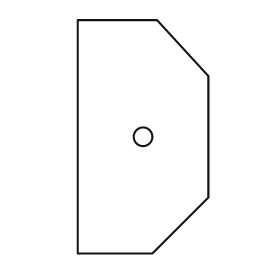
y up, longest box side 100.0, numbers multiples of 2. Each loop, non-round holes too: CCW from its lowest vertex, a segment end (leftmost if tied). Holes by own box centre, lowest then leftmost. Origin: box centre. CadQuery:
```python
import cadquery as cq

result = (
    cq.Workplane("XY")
    .moveTo(-28.0, -50.0)
    .lineTo(4.0, -50.0)
    .lineTo(28.0, -26.0)
    .lineTo(28.0, 26.0)
    .lineTo(6.0, 50.0)
    .lineTo(-28.0, 50.0)
    .close()
    .moveTo(0.0, 0.0)
    .circle(4.0)
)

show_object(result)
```